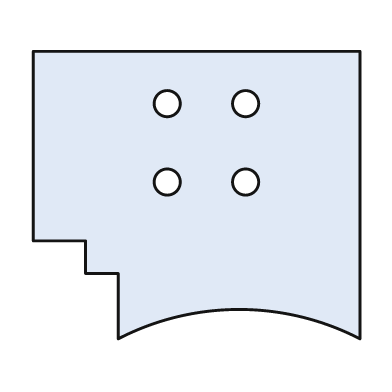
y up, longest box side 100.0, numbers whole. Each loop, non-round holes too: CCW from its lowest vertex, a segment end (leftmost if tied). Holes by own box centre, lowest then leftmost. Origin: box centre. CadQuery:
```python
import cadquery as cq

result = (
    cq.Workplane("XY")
    .moveTo(-24.0, -44.0)
    .threePointArc((13.0, -35.0), (50.0, -44.0))
    .lineTo(50.0, 44.0)
    .lineTo(-50.0, 44.0)
    .lineTo(-50.0, -14.0)
    .lineTo(-34.0, -14.0)
    .lineTo(-34.0, -24.0)
    .lineTo(-24.0, -24.0)
    .close()
    .moveTo(-9.0, 4.0)
    .circle(4.0)
    .moveTo(15.0, 4.0)
    .circle(4.0)
    .moveTo(-9.0, 28.0)
    .circle(4.0)
    .moveTo(15.0, 28.0)
    .circle(4.0)
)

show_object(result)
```